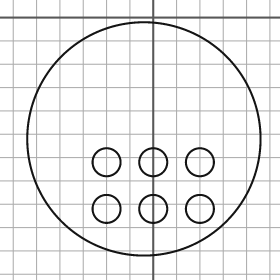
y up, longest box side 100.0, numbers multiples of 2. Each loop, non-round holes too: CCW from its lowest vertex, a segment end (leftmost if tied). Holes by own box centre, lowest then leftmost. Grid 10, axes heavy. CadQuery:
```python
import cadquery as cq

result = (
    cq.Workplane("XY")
    .moveTo(-4.0, -52.0)
    .circle(50.0)
    .moveTo(-20.0, -82.0)
    .circle(6.0)
    .moveTo(0.0, -82.0)
    .circle(6.0)
    .moveTo(20.0, -82.0)
    .circle(6.0)
    .moveTo(-20.0, -62.0)
    .circle(6.0)
    .moveTo(0.0, -62.0)
    .circle(6.0)
    .moveTo(20.0, -62.0)
    .circle(6.0)
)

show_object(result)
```